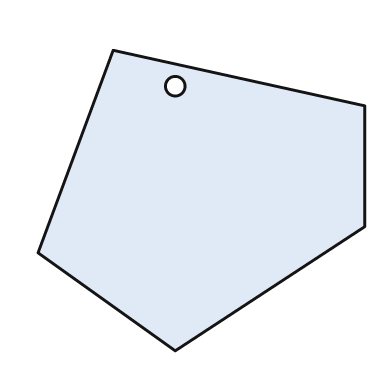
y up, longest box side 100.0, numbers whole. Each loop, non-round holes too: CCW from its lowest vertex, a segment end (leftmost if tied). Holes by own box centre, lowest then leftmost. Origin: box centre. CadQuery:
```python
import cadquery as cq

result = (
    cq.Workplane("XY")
    .moveTo(-8.0, -46.0)
    .lineTo(50.0, -8.0)
    .lineTo(50.0, 29.0)
    .lineTo(-27.0, 46.0)
    .lineTo(-50.0, -16.0)
    .close()
    .moveTo(-8.0, 35.0)
    .circle(3.0)
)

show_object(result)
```